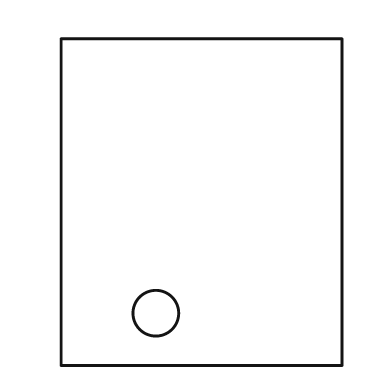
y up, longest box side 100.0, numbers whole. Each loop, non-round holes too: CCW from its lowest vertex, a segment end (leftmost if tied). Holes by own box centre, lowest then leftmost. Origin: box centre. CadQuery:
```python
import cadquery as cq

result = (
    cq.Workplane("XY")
    .moveTo(-43.0, -50.0)
    .lineTo(43.0, -50.0)
    .lineTo(43.0, 50.0)
    .lineTo(-43.0, 50.0)
    .close()
    .moveTo(-14.0, -34.0)
    .circle(7.0)
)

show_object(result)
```